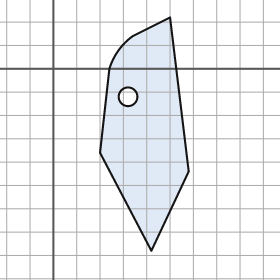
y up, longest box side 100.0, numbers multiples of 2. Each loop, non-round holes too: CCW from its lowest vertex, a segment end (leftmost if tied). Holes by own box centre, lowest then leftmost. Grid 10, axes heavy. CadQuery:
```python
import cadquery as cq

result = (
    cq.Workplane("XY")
    .moveTo(42.0, -78.0)
    .lineTo(58.0, -44.0)
    .lineTo(50.0, 22.0)
    .lineTo(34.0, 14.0)
    .threePointArc((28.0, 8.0), (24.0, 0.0))
    .lineTo(20.0, -36.0)
    .close()
    .moveTo(32.0, -12.0)
    .circle(4.0)
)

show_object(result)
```